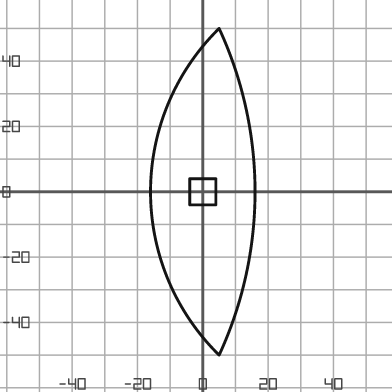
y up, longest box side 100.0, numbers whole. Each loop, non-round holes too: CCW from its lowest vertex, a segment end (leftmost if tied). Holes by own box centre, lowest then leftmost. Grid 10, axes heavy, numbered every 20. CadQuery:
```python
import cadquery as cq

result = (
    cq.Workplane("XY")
    .moveTo(5.0, -50.0)
    .threePointArc((16.0, 0.0), (5.0, 50.0))
    .threePointArc((-16.0, 0.0), (5.0, -50.0))
    .close()
    .moveTo(-4.0, -4.0)
    .lineTo(4.0, -4.0)
    .lineTo(4.0, 4.0)
    .lineTo(-4.0, 4.0)
    .close()
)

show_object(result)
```